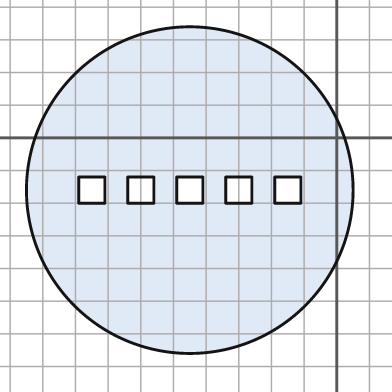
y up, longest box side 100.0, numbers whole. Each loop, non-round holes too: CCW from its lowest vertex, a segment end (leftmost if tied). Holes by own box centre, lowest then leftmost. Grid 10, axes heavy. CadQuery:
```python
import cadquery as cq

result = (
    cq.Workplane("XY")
    .moveTo(-45.0, -16.0)
    .circle(50.0)
    .moveTo(-79.0, -20.0)
    .lineTo(-71.0, -20.0)
    .lineTo(-71.0, -12.0)
    .lineTo(-79.0, -12.0)
    .close()
    .moveTo(-64.0, -20.0)
    .lineTo(-56.0, -20.0)
    .lineTo(-56.0, -12.0)
    .lineTo(-64.0, -12.0)
    .close()
    .moveTo(-49.0, -20.0)
    .lineTo(-41.0, -20.0)
    .lineTo(-41.0, -12.0)
    .lineTo(-49.0, -12.0)
    .close()
    .moveTo(-34.0, -20.0)
    .lineTo(-26.0, -20.0)
    .lineTo(-26.0, -12.0)
    .lineTo(-34.0, -12.0)
    .close()
    .moveTo(-19.0, -20.0)
    .lineTo(-11.0, -20.0)
    .lineTo(-11.0, -12.0)
    .lineTo(-19.0, -12.0)
    .close()
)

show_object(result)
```